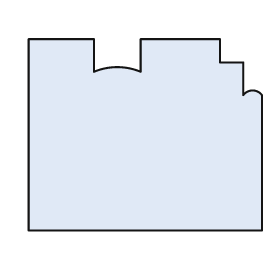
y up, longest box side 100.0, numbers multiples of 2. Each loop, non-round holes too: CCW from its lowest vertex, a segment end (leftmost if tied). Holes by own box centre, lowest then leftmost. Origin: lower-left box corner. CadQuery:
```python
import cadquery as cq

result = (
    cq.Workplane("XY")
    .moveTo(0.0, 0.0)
    .lineTo(100.0, 0.0)
    .lineTo(100.0, 58.0)
    .threePointArc((96.0, 60.0), (92.0, 58.0))
    .lineTo(92.0, 72.0)
    .lineTo(82.0, 72.0)
    .lineTo(82.0, 82.0)
    .lineTo(48.0, 82.0)
    .lineTo(48.0, 68.0)
    .threePointArc((38.0, 70.0), (28.0, 68.0))
    .lineTo(28.0, 82.0)
    .lineTo(0.0, 82.0)
    .close()
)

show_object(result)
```